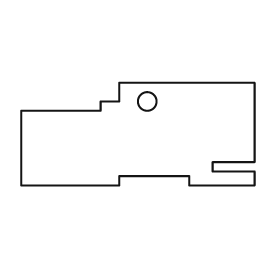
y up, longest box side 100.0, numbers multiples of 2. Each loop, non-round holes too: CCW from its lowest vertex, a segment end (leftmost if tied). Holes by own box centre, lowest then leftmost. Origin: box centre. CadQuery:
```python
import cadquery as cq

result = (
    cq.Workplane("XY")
    .moveTo(-50.0, -22.0)
    .lineTo(-8.0, -22.0)
    .lineTo(-8.0, -18.0)
    .lineTo(22.0, -18.0)
    .lineTo(22.0, -22.0)
    .lineTo(50.0, -22.0)
    .lineTo(50.0, -16.0)
    .lineTo(32.0, -16.0)
    .lineTo(32.0, -12.0)
    .lineTo(50.0, -12.0)
    .lineTo(50.0, 22.0)
    .lineTo(-8.0, 22.0)
    .lineTo(-8.0, 14.0)
    .lineTo(-16.0, 14.0)
    .lineTo(-16.0, 10.0)
    .lineTo(-50.0, 10.0)
    .close()
    .moveTo(4.0, 14.0)
    .circle(4.0)
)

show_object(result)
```